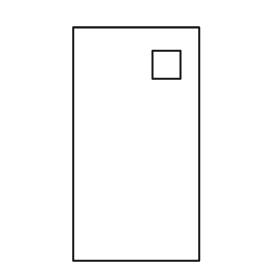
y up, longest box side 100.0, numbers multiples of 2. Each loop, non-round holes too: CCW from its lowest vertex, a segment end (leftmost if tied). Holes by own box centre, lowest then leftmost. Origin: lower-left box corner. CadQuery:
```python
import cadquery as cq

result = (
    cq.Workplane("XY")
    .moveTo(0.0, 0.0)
    .lineTo(54.0, 0.0)
    .lineTo(54.0, 100.0)
    .lineTo(0.0, 100.0)
    .close()
    .moveTo(34.0, 78.0)
    .lineTo(46.0, 78.0)
    .lineTo(46.0, 90.0)
    .lineTo(34.0, 90.0)
    .close()
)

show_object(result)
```